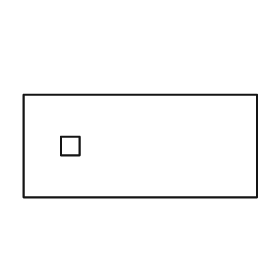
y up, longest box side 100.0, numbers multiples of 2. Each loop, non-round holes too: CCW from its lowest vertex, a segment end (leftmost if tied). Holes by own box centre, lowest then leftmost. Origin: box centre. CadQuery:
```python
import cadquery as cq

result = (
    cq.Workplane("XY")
    .moveTo(-50.0, -22.0)
    .lineTo(50.0, -22.0)
    .lineTo(50.0, 22.0)
    .lineTo(-50.0, 22.0)
    .close()
    .moveTo(-34.0, -4.0)
    .lineTo(-26.0, -4.0)
    .lineTo(-26.0, 4.0)
    .lineTo(-34.0, 4.0)
    .close()
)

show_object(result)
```